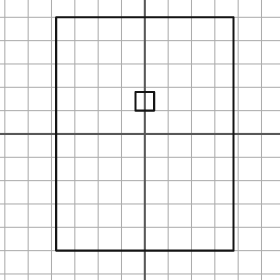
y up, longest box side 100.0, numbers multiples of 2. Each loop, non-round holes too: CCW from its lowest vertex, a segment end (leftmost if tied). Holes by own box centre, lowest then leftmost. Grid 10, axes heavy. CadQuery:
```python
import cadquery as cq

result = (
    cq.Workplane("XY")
    .moveTo(-38.0, -50.0)
    .lineTo(38.0, -50.0)
    .lineTo(38.0, 50.0)
    .lineTo(-38.0, 50.0)
    .close()
    .moveTo(-4.0, 10.0)
    .lineTo(4.0, 10.0)
    .lineTo(4.0, 18.0)
    .lineTo(-4.0, 18.0)
    .close()
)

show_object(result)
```